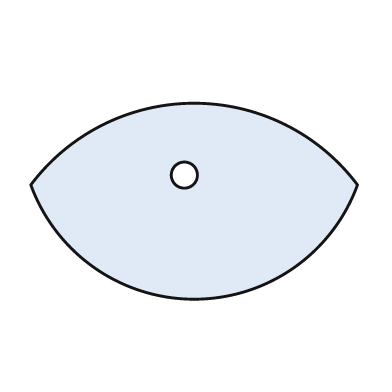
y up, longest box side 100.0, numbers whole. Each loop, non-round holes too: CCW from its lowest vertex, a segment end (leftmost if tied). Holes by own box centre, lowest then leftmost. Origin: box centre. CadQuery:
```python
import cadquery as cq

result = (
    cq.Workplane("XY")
    .moveTo(-50.0, 5.0)
    .threePointArc((0.0, -30.0), (50.0, 5.0))
    .threePointArc((0.0, 30.0), (-50.0, 5.0))
    .close()
    .moveTo(-3.0, 8.0)
    .circle(4.0)
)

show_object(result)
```